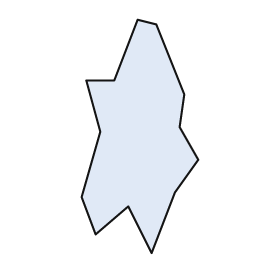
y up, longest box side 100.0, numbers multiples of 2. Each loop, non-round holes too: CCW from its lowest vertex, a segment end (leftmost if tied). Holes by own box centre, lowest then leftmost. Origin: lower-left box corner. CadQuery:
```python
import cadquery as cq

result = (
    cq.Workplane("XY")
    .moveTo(30.0, 0.0)
    .lineTo(40.0, 26.0)
    .lineTo(50.0, 40.0)
    .lineTo(42.0, 54.0)
    .lineTo(44.0, 68.0)
    .lineTo(32.0, 98.0)
    .lineTo(24.0, 100.0)
    .lineTo(14.0, 74.0)
    .lineTo(2.0, 74.0)
    .lineTo(8.0, 52.0)
    .lineTo(0.0, 24.0)
    .lineTo(6.0, 8.0)
    .lineTo(20.0, 20.0)
    .close()
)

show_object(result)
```